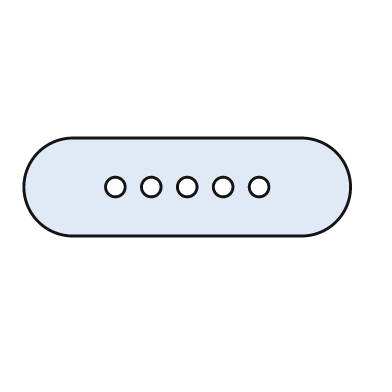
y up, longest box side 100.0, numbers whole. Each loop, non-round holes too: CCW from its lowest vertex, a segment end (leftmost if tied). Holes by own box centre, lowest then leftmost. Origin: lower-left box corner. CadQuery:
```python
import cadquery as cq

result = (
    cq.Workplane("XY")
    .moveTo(15.0, 0.0)
    .lineTo(85.0, 0.0)
    .threePointArc((100.0, 15.0), (85.0, 30.0))
    .lineTo(15.0, 30.0)
    .threePointArc((0.0, 15.0), (15.0, 0.0))
    .close()
    .moveTo(28.0, 15.0)
    .circle(3.0)
    .moveTo(39.0, 15.0)
    .circle(3.0)
    .moveTo(50.0, 15.0)
    .circle(3.0)
    .moveTo(61.0, 15.0)
    .circle(3.0)
    .moveTo(72.0, 15.0)
    .circle(3.0)
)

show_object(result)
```